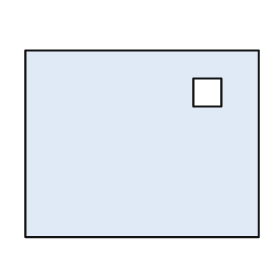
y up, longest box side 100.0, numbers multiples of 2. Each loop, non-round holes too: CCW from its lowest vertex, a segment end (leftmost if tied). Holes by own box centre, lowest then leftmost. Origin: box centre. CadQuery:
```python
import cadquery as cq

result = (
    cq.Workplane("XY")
    .moveTo(-50.0, -40.0)
    .lineTo(50.0, -40.0)
    .lineTo(50.0, 40.0)
    .lineTo(-50.0, 40.0)
    .close()
    .moveTo(22.0, 16.0)
    .lineTo(34.0, 16.0)
    .lineTo(34.0, 28.0)
    .lineTo(22.0, 28.0)
    .close()
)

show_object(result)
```